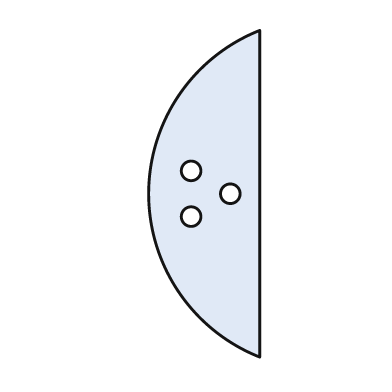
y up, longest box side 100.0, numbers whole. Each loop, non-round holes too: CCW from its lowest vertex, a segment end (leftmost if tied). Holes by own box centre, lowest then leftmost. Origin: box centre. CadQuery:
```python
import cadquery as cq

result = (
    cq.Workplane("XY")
    .moveTo(17.0, -50.0)
    .lineTo(17.0, 50.0)
    .threePointArc((-17.0, 0.0), (17.0, -50.0))
    .close()
    .moveTo(-4.0, -7.0)
    .circle(3.0)
    .moveTo(8.0, 0.0)
    .circle(3.0)
    .moveTo(-4.0, 7.0)
    .circle(3.0)
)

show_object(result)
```